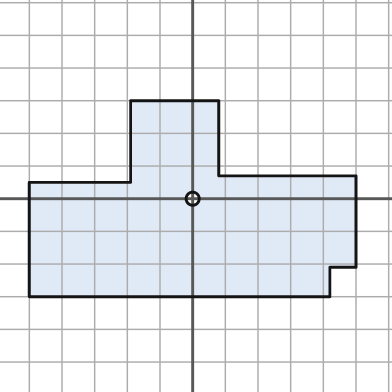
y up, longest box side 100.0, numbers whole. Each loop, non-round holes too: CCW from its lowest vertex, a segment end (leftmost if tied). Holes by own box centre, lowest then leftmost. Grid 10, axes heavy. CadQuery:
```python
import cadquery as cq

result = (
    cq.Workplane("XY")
    .moveTo(-50.0, -30.0)
    .lineTo(42.0, -30.0)
    .lineTo(42.0, -21.0)
    .lineTo(50.0, -21.0)
    .lineTo(50.0, 7.0)
    .lineTo(8.0, 7.0)
    .lineTo(8.0, 30.0)
    .lineTo(-19.0, 30.0)
    .lineTo(-19.0, 5.0)
    .lineTo(-50.0, 5.0)
    .close()
    .moveTo(0.0, 0.0)
    .circle(2.0)
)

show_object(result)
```